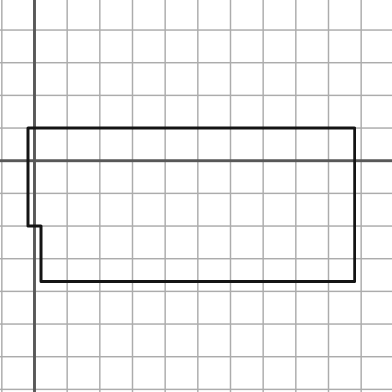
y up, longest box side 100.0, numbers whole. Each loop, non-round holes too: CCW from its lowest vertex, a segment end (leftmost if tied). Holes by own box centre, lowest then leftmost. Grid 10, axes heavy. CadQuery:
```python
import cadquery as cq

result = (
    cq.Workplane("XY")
    .moveTo(2.0, -37.0)
    .lineTo(98.0, -37.0)
    .lineTo(98.0, 10.0)
    .lineTo(-2.0, 10.0)
    .lineTo(-2.0, -20.0)
    .lineTo(2.0, -20.0)
    .close()
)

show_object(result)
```